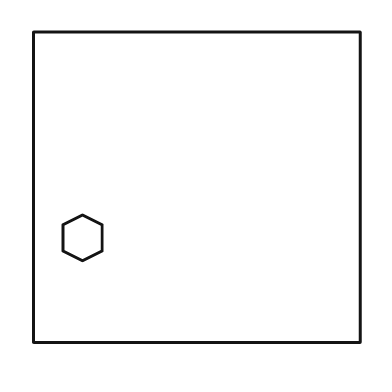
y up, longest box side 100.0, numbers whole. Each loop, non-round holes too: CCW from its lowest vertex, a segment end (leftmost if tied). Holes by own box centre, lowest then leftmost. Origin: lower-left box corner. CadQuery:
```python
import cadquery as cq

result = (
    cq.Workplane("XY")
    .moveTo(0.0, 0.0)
    .lineTo(100.0, 0.0)
    .lineTo(100.0, 95.0)
    .lineTo(0.0, 95.0)
    .close()
    .moveTo(15.0, 25.0)
    .lineTo(21.0, 28.0)
    .lineTo(21.0, 36.0)
    .lineTo(15.0, 39.0)
    .lineTo(9.0, 36.0)
    .lineTo(9.0, 28.0)
    .close()
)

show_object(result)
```